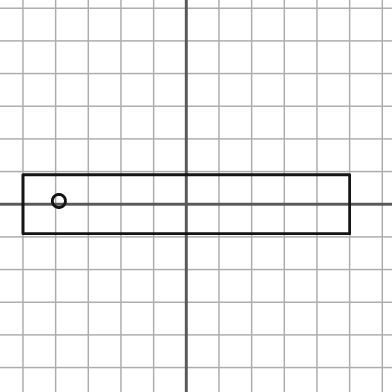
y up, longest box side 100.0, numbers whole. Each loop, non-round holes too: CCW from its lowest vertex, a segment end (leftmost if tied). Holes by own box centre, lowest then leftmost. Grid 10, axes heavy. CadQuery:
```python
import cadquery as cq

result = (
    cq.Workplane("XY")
    .moveTo(-50.0, -9.0)
    .lineTo(50.0, -9.0)
    .lineTo(50.0, 9.0)
    .lineTo(-50.0, 9.0)
    .close()
    .moveTo(-39.0, 1.0)
    .circle(2.0)
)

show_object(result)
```